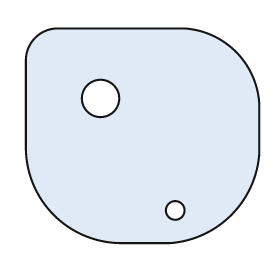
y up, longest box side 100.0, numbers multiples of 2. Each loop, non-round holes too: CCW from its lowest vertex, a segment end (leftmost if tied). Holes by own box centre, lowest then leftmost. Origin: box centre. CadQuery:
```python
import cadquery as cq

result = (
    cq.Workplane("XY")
    .moveTo(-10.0, -46.0)
    .lineTo(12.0, -46.0)
    .threePointArc((38.0, -34.0), (50.0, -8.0))
    .lineTo(50.0, 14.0)
    .threePointArc((40.0, 36.0), (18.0, 46.0))
    .lineTo(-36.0, 46.0)
    .threePointArc((-46.0, 42.0), (-50.0, 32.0))
    .lineTo(-50.0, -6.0)
    .threePointArc((-38.0, -34.0), (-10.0, -46.0))
    .close()
    .moveTo(14.0, -32.0)
    .circle(4.0)
    .moveTo(-18.0, 16.0)
    .circle(8.0)
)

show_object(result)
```